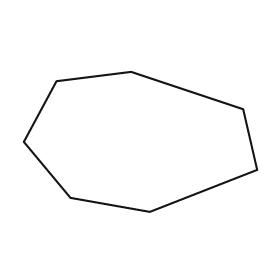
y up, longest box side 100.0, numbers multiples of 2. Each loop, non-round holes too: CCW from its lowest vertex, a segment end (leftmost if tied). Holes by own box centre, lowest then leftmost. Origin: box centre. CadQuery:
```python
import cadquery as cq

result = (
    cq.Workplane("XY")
    .moveTo(4.0, -30.0)
    .lineTo(50.0, -12.0)
    .lineTo(44.0, 14.0)
    .lineTo(-4.0, 30.0)
    .lineTo(-36.0, 26.0)
    .lineTo(-50.0, 0.0)
    .lineTo(-30.0, -24.0)
    .close()
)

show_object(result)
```